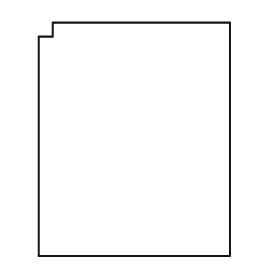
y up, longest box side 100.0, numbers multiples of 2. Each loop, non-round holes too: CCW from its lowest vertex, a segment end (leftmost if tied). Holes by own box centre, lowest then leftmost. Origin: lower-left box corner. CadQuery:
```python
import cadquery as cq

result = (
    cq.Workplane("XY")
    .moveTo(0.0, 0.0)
    .lineTo(82.0, 0.0)
    .lineTo(82.0, 100.0)
    .lineTo(6.0, 100.0)
    .lineTo(6.0, 94.0)
    .lineTo(0.0, 94.0)
    .close()
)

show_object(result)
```